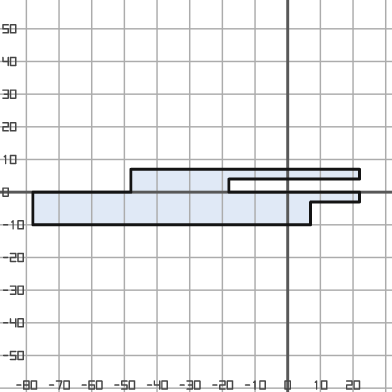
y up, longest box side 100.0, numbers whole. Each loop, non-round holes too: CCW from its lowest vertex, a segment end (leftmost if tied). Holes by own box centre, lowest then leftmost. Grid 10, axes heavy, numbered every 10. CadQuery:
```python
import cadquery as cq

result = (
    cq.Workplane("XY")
    .moveTo(-78.0, -10.0)
    .lineTo(7.0, -10.0)
    .lineTo(7.0, -3.0)
    .lineTo(22.0, -3.0)
    .lineTo(22.0, 0.0)
    .lineTo(-18.0, 0.0)
    .lineTo(-18.0, 4.0)
    .lineTo(22.0, 4.0)
    .lineTo(22.0, 7.0)
    .lineTo(-48.0, 7.0)
    .lineTo(-48.0, 0.0)
    .lineTo(-78.0, 0.0)
    .close()
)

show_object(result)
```